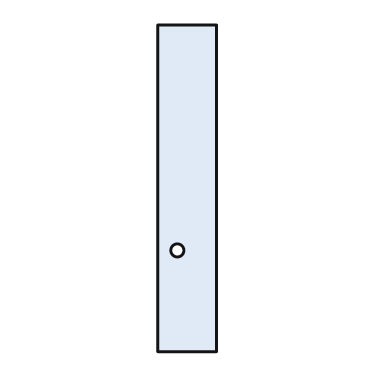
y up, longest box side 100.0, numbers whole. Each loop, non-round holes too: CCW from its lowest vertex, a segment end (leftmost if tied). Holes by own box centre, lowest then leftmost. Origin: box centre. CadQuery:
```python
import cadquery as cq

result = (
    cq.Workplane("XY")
    .moveTo(-9.0, -50.0)
    .lineTo(9.0, -50.0)
    .lineTo(9.0, 50.0)
    .lineTo(-9.0, 50.0)
    .close()
    .moveTo(-3.0, -19.0)
    .circle(2.0)
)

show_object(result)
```